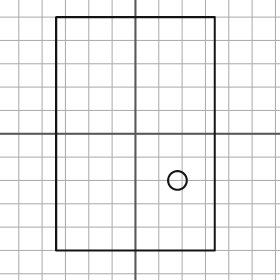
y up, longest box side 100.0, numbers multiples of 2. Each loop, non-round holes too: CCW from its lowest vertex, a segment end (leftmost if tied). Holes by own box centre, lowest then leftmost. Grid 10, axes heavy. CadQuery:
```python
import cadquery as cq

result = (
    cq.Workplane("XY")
    .moveTo(-34.0, -50.0)
    .lineTo(34.0, -50.0)
    .lineTo(34.0, 50.0)
    .lineTo(-34.0, 50.0)
    .close()
    .moveTo(18.0, -20.0)
    .circle(4.0)
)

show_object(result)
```